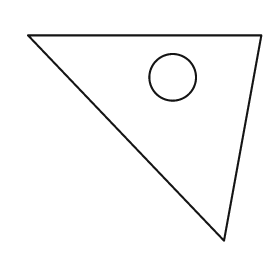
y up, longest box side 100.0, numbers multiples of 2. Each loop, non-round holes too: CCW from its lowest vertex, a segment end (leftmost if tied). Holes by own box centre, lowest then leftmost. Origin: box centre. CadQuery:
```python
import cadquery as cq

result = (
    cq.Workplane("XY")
    .moveTo(34.0, -44.0)
    .lineTo(50.0, 44.0)
    .lineTo(-50.0, 44.0)
    .close()
    .moveTo(12.0, 26.0)
    .circle(10.0)
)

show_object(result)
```